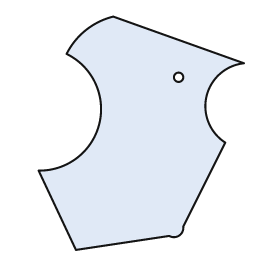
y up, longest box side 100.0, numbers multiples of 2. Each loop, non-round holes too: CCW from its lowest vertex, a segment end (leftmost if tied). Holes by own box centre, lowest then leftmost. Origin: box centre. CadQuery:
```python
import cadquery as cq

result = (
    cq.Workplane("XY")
    .moveTo(-28.0, -50.0)
    .lineTo(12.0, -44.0)
    .threePointArc((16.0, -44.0), (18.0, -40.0))
    .lineTo(36.0, -4.0)
    .threePointArc((28.0, 16.0), (44.0, 30.0))
    .lineTo(-12.0, 50.0)
    .threePointArc((-24.0, 44.0), (-32.0, 34.0))
    .threePointArc((-18.0, 4.0), (-44.0, -16.0))
    .close()
    .moveTo(16.0, 24.0)
    .circle(2.0)
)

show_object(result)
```